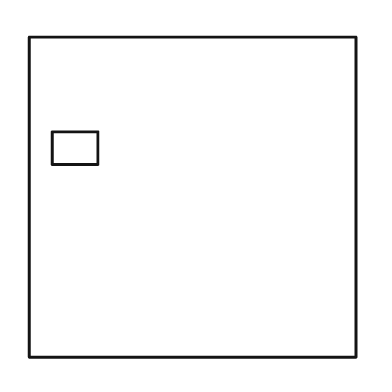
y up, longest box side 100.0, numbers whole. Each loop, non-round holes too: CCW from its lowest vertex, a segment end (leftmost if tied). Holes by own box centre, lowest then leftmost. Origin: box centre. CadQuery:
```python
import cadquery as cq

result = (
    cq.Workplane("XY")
    .moveTo(-50.0, -49.0)
    .lineTo(50.0, -49.0)
    .lineTo(50.0, 49.0)
    .lineTo(-50.0, 49.0)
    .close()
    .moveTo(-43.0, 10.0)
    .lineTo(-29.0, 10.0)
    .lineTo(-29.0, 20.0)
    .lineTo(-43.0, 20.0)
    .close()
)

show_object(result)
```